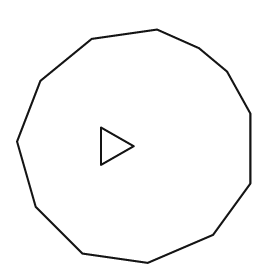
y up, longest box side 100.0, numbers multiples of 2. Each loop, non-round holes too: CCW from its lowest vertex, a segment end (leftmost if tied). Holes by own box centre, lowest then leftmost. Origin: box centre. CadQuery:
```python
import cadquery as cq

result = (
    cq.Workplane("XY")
    .moveTo(6.0, -50.0)
    .lineTo(34.0, -38.0)
    .lineTo(50.0, -16.0)
    .lineTo(50.0, 14.0)
    .lineTo(40.0, 32.0)
    .lineTo(28.0, 42.0)
    .lineTo(10.0, 50.0)
    .lineTo(-18.0, 46.0)
    .lineTo(-40.0, 28.0)
    .lineTo(-50.0, 2.0)
    .lineTo(-42.0, -26.0)
    .lineTo(-22.0, -46.0)
    .close()
    .moveTo(-14.0, -8.0)
    .lineTo(0.0, 0.0)
    .lineTo(-14.0, 8.0)
    .close()
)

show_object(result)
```